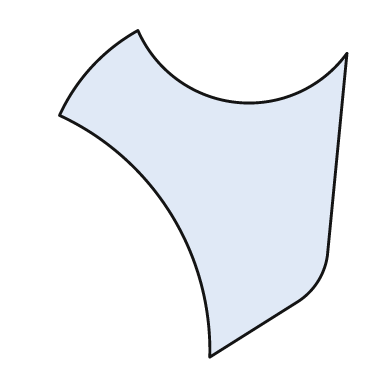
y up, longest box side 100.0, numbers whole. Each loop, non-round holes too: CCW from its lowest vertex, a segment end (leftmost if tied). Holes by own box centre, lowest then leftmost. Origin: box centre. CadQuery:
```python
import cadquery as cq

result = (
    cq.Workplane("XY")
    .moveTo(2.0, -50.0)
    .lineTo(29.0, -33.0)
    .threePointArc((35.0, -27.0), (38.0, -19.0))
    .lineTo(44.0, 43.0)
    .threePointArc((10.0, 28.0), (-20.0, 50.0))
    .threePointArc((-34.0, 39.0), (-44.0, 24.0))
    .threePointArc((-10.0, -6.0), (2.0, -50.0))
    .close()
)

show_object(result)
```